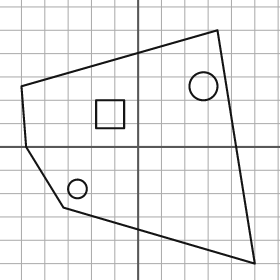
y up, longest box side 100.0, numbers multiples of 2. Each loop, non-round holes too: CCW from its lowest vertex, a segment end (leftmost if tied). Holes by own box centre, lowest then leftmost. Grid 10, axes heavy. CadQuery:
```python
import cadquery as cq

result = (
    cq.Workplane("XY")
    .moveTo(50.0, -50.0)
    .lineTo(34.0, 50.0)
    .lineTo(-50.0, 26.0)
    .lineTo(-48.0, 0.0)
    .lineTo(-32.0, -26.0)
    .close()
    .moveTo(-26.0, -18.0)
    .circle(4.0)
    .moveTo(-18.0, 8.0)
    .lineTo(-6.0, 8.0)
    .lineTo(-6.0, 20.0)
    .lineTo(-18.0, 20.0)
    .close()
    .moveTo(28.0, 26.0)
    .circle(6.0)
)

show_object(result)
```